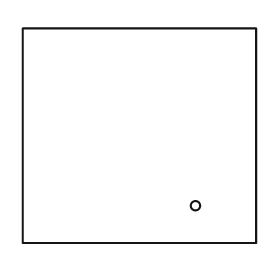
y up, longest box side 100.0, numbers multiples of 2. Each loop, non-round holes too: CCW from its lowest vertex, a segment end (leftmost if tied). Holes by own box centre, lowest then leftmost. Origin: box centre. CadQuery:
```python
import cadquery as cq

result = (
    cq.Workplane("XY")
    .moveTo(-50.0, -46.0)
    .lineTo(50.0, -46.0)
    .lineTo(50.0, 46.0)
    .lineTo(-50.0, 46.0)
    .close()
    .moveTo(24.0, -30.0)
    .circle(2.0)
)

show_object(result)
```